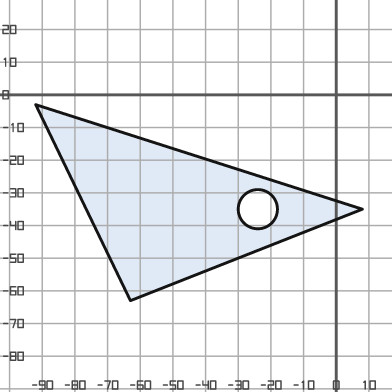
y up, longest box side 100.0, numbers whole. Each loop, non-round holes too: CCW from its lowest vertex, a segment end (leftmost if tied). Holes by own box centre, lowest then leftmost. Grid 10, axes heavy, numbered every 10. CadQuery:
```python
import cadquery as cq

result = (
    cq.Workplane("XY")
    .moveTo(-63.0, -63.0)
    .lineTo(8.0, -35.0)
    .lineTo(-92.0, -3.0)
    .close()
    .moveTo(-24.0, -35.0)
    .circle(6.0)
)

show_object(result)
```